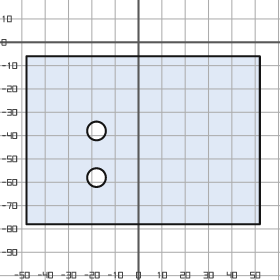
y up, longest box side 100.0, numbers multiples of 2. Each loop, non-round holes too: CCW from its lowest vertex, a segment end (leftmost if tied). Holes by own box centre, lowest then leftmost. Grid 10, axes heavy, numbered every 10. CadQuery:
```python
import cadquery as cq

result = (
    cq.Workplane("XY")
    .moveTo(-48.0, -78.0)
    .lineTo(52.0, -78.0)
    .lineTo(52.0, -6.0)
    .lineTo(-48.0, -6.0)
    .close()
    .moveTo(-18.0, -58.0)
    .circle(4.0)
    .moveTo(-18.0, -38.0)
    .circle(4.0)
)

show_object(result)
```